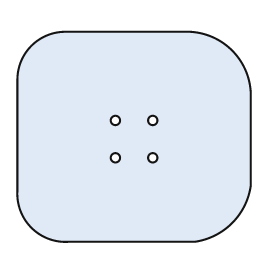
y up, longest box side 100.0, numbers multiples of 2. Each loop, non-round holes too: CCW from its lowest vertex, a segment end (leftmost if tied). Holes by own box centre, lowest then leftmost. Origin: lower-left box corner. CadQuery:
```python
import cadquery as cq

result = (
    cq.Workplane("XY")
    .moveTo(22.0, 0.0)
    .lineTo(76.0, 0.0)
    .threePointArc((92.0, 8.0), (100.0, 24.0))
    .lineTo(100.0, 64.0)
    .threePointArc((92.0, 82.0), (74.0, 90.0))
    .lineTo(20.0, 90.0)
    .threePointArc((6.0, 84.0), (0.0, 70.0))
    .lineTo(0.0, 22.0)
    .threePointArc((6.0, 6.0), (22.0, 0.0))
    .close()
    .moveTo(42.0, 36.0)
    .circle(2.0)
    .moveTo(58.0, 36.0)
    .circle(2.0)
    .moveTo(42.0, 52.0)
    .circle(2.0)
    .moveTo(58.0, 52.0)
    .circle(2.0)
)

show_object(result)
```